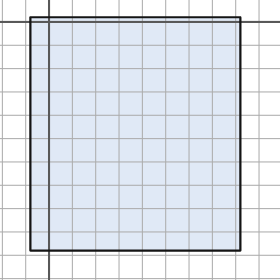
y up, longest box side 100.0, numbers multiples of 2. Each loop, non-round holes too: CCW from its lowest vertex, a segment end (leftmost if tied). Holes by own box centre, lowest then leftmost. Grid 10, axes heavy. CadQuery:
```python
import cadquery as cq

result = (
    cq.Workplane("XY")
    .moveTo(-8.0, -98.0)
    .lineTo(82.0, -98.0)
    .lineTo(82.0, 2.0)
    .lineTo(-8.0, 2.0)
    .close()
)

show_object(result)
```